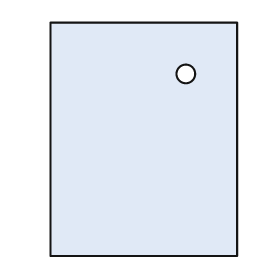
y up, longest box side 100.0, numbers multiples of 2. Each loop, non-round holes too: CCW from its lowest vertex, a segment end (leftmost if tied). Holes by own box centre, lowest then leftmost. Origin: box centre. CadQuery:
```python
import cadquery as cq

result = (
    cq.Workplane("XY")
    .moveTo(-40.0, -50.0)
    .lineTo(40.0, -50.0)
    .lineTo(40.0, 50.0)
    .lineTo(-40.0, 50.0)
    .close()
    .moveTo(18.0, 28.0)
    .circle(4.0)
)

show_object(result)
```